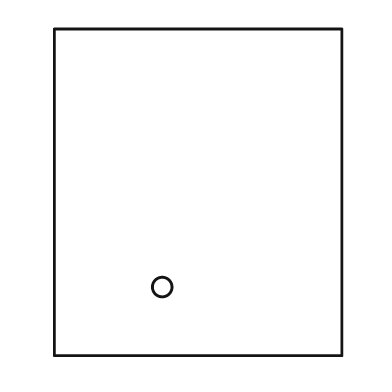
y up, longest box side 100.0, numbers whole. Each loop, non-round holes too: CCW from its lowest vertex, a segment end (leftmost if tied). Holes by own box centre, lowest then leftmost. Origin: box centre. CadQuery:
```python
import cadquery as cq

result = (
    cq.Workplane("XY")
    .moveTo(-44.0, -50.0)
    .lineTo(44.0, -50.0)
    .lineTo(44.0, 50.0)
    .lineTo(-44.0, 50.0)
    .close()
    .moveTo(-11.0, -29.0)
    .circle(3.0)
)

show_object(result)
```